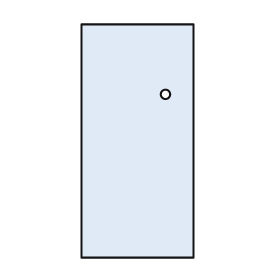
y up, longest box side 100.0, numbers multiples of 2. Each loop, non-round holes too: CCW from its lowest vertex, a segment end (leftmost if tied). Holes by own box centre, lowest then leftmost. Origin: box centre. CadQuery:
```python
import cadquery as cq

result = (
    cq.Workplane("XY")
    .moveTo(-24.0, -50.0)
    .lineTo(24.0, -50.0)
    .lineTo(24.0, 50.0)
    .lineTo(-24.0, 50.0)
    .close()
    .moveTo(12.0, 20.0)
    .circle(2.0)
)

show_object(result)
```